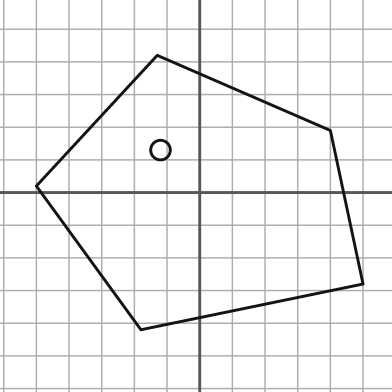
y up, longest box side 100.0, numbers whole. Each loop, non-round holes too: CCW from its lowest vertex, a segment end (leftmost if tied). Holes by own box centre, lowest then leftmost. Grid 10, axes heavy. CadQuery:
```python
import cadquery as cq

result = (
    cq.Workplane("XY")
    .moveTo(-18.0, -42.0)
    .lineTo(50.0, -28.0)
    .lineTo(40.0, 19.0)
    .lineTo(-13.0, 42.0)
    .lineTo(-50.0, 2.0)
    .close()
    .moveTo(-12.0, 13.0)
    .circle(3.0)
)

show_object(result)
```